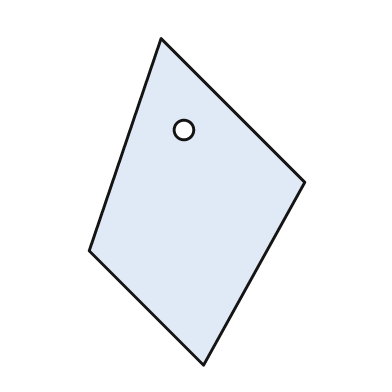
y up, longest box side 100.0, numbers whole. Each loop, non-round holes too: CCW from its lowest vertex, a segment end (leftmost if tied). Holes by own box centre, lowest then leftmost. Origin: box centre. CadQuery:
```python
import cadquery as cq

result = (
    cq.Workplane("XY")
    .moveTo(2.0, -50.0)
    .lineTo(33.0, 6.0)
    .lineTo(-11.0, 50.0)
    .lineTo(-33.0, -15.0)
    .close()
    .moveTo(-4.0, 22.0)
    .circle(3.0)
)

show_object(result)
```